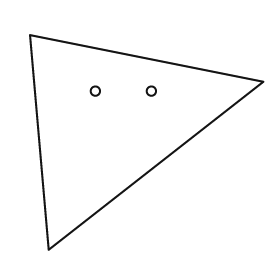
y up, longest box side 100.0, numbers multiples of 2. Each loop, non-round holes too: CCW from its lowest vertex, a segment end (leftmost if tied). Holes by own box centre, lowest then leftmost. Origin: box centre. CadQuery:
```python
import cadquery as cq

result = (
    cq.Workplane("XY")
    .moveTo(-42.0, -46.0)
    .lineTo(50.0, 26.0)
    .lineTo(-50.0, 46.0)
    .close()
    .moveTo(-22.0, 22.0)
    .circle(2.0)
    .moveTo(2.0, 22.0)
    .circle(2.0)
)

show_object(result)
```